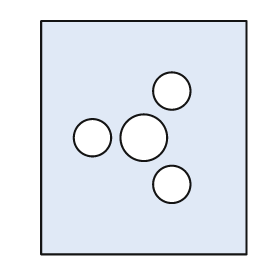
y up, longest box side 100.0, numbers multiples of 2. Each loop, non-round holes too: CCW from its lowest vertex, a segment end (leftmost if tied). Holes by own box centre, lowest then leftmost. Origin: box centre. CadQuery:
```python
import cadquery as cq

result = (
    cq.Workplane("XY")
    .moveTo(-44.0, -50.0)
    .lineTo(44.0, -50.0)
    .lineTo(44.0, 50.0)
    .lineTo(-44.0, 50.0)
    .close()
    .moveTo(12.0, -20.0)
    .circle(8.0)
    .moveTo(-22.0, 0.0)
    .circle(8.0)
    .moveTo(0.0, 0.0)
    .circle(10.0)
    .moveTo(12.0, 20.0)
    .circle(8.0)
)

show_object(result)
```